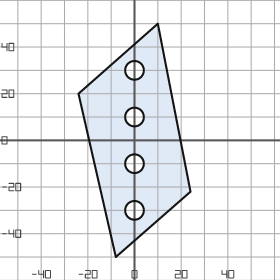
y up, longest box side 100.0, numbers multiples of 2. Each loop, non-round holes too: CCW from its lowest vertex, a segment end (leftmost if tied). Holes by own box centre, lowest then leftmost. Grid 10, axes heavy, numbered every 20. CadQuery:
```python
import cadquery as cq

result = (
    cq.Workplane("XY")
    .moveTo(-8.0, -50.0)
    .lineTo(24.0, -22.0)
    .lineTo(10.0, 50.0)
    .lineTo(-24.0, 20.0)
    .close()
    .moveTo(0.0, -30.0)
    .circle(4.0)
    .moveTo(0.0, -10.0)
    .circle(4.0)
    .moveTo(0.0, 10.0)
    .circle(4.0)
    .moveTo(0.0, 30.0)
    .circle(4.0)
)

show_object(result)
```